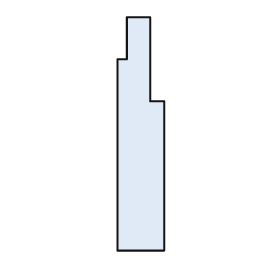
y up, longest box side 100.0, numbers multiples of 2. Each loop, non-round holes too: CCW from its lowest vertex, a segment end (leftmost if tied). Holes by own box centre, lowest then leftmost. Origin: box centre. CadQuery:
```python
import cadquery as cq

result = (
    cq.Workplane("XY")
    .moveTo(-10.0, -50.0)
    .lineTo(10.0, -50.0)
    .lineTo(10.0, 14.0)
    .lineTo(4.0, 14.0)
    .lineTo(4.0, 50.0)
    .lineTo(-6.0, 50.0)
    .lineTo(-6.0, 32.0)
    .lineTo(-10.0, 32.0)
    .close()
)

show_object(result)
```